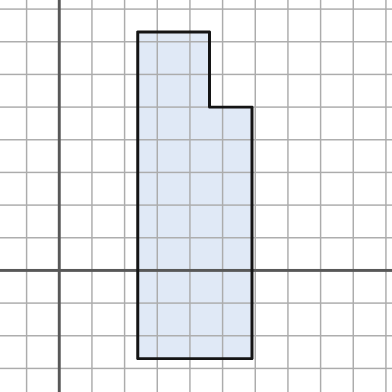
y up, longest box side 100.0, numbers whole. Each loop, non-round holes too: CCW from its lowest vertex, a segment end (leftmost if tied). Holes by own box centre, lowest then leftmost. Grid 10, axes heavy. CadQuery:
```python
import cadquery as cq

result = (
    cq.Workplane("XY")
    .moveTo(24.0, -27.0)
    .lineTo(59.0, -27.0)
    .lineTo(59.0, 50.0)
    .lineTo(46.0, 50.0)
    .lineTo(46.0, 73.0)
    .lineTo(24.0, 73.0)
    .close()
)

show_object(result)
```